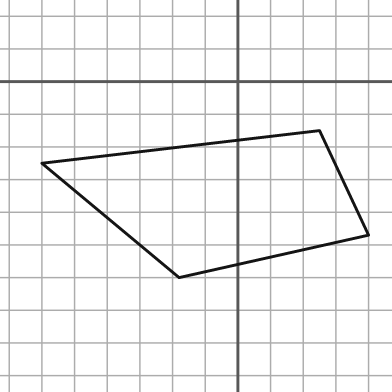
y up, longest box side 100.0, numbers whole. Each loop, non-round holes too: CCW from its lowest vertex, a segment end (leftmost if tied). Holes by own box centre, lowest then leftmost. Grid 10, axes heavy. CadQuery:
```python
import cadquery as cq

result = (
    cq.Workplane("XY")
    .moveTo(-18.0, -60.0)
    .lineTo(40.0, -47.0)
    .lineTo(25.0, -15.0)
    .lineTo(-60.0, -25.0)
    .close()
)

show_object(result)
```